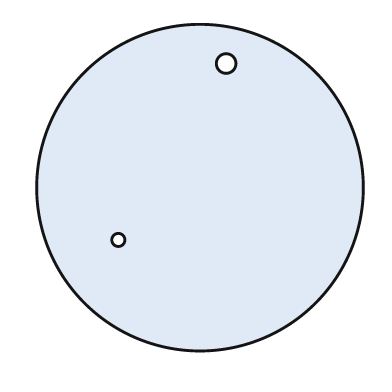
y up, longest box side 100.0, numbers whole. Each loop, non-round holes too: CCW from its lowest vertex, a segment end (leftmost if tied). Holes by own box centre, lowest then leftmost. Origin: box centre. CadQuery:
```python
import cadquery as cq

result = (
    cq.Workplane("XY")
    .moveTo(0.0, 0.0)
    .circle(50.0)
    .moveTo(-25.0, -16.0)
    .circle(2.0)
    .moveTo(8.0, 38.0)
    .circle(3.0)
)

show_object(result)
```